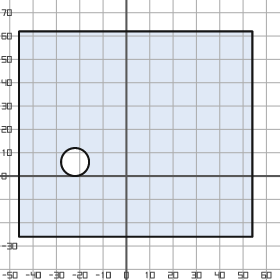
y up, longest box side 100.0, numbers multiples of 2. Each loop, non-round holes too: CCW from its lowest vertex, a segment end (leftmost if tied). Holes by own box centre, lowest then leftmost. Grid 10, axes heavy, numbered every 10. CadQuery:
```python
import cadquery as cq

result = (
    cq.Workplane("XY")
    .moveTo(-46.0, -26.0)
    .lineTo(54.0, -26.0)
    .lineTo(54.0, 62.0)
    .lineTo(-46.0, 62.0)
    .close()
    .moveTo(-22.0, 6.0)
    .circle(6.0)
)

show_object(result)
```